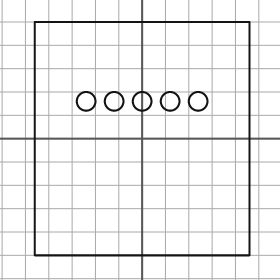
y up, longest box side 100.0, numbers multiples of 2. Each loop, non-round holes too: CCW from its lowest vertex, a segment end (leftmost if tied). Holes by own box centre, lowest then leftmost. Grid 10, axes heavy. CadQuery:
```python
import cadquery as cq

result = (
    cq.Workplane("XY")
    .moveTo(-46.0, -50.0)
    .lineTo(46.0, -50.0)
    .lineTo(46.0, 50.0)
    .lineTo(-46.0, 50.0)
    .close()
    .moveTo(-24.0, 16.0)
    .circle(4.0)
    .moveTo(-12.0, 16.0)
    .circle(4.0)
    .moveTo(0.0, 16.0)
    .circle(4.0)
    .moveTo(12.0, 16.0)
    .circle(4.0)
    .moveTo(24.0, 16.0)
    .circle(4.0)
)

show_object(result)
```